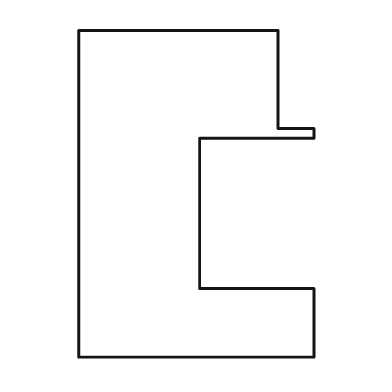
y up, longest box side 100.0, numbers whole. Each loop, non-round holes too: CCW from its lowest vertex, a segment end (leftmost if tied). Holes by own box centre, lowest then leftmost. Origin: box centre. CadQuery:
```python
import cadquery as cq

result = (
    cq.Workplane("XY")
    .moveTo(-36.0, -50.0)
    .lineTo(36.0, -50.0)
    .lineTo(36.0, -29.0)
    .lineTo(1.0, -29.0)
    .lineTo(1.0, 17.0)
    .lineTo(36.0, 17.0)
    .lineTo(36.0, 20.0)
    .lineTo(25.0, 20.0)
    .lineTo(25.0, 50.0)
    .lineTo(-36.0, 50.0)
    .close()
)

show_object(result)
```